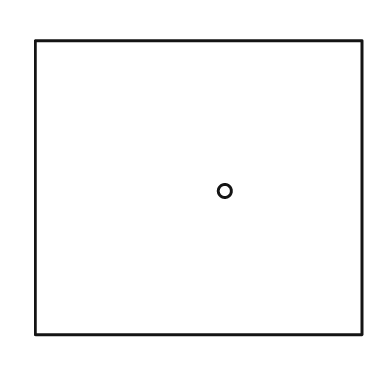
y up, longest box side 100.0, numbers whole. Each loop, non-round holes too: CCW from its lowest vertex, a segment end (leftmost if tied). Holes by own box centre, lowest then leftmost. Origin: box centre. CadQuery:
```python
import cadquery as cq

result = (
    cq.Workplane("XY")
    .moveTo(-50.0, -45.0)
    .lineTo(50.0, -45.0)
    .lineTo(50.0, 45.0)
    .lineTo(-50.0, 45.0)
    .close()
    .moveTo(8.0, -1.0)
    .circle(2.0)
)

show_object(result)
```